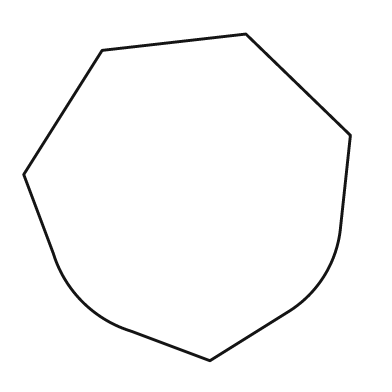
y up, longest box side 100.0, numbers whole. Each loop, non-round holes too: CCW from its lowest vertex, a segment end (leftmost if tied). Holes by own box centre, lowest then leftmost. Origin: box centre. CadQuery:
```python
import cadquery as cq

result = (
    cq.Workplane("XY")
    .moveTo(7.0, -50.0)
    .lineTo(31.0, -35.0)
    .threePointArc((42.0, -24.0), (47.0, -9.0))
    .lineTo(50.0, 19.0)
    .lineTo(18.0, 50.0)
    .lineTo(-26.0, 45.0)
    .lineTo(-50.0, 7.0)
    .lineTo(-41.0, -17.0)
    .threePointArc((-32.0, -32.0), (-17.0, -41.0))
    .close()
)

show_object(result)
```